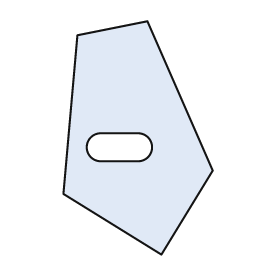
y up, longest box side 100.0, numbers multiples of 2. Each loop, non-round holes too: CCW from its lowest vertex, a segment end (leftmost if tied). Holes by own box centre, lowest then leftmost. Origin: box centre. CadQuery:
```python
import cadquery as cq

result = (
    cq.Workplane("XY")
    .moveTo(10.0, -50.0)
    .lineTo(32.0, -14.0)
    .lineTo(4.0, 50.0)
    .lineTo(-26.0, 44.0)
    .lineTo(-32.0, -24.0)
    .close()
    .moveTo(-16.0, -10.0)
    .lineTo(0.0, -10.0)
    .threePointArc((6.0, -4.0), (0.0, 2.0))
    .lineTo(-16.0, 2.0)
    .threePointArc((-22.0, -4.0), (-16.0, -10.0))
    .close()
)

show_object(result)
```